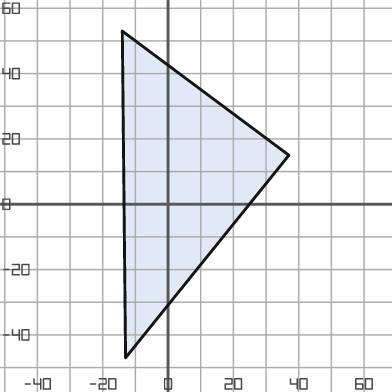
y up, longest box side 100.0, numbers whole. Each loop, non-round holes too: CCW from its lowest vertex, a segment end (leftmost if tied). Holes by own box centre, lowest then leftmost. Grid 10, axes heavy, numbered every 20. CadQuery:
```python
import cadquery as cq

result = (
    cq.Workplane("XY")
    .moveTo(-13.0, -47.0)
    .lineTo(37.0, 15.0)
    .lineTo(-14.0, 53.0)
    .close()
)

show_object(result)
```